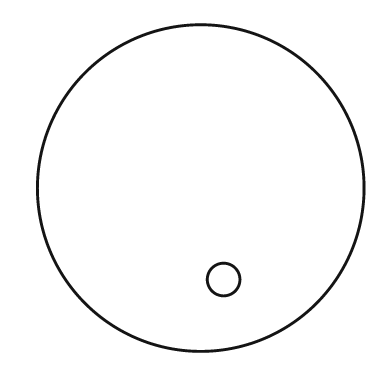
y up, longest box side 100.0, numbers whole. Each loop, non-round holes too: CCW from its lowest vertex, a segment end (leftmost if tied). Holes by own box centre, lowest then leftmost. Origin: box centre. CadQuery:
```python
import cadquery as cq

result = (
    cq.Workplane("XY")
    .moveTo(0.0, 0.0)
    .circle(50.0)
    .moveTo(7.0, -28.0)
    .circle(5.0)
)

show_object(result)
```